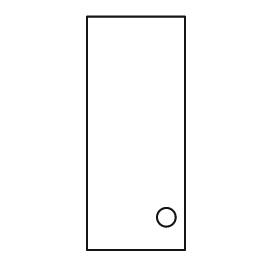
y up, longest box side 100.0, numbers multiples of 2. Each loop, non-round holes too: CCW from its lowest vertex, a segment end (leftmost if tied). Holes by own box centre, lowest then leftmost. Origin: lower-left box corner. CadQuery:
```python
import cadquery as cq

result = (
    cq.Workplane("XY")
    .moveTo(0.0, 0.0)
    .lineTo(42.0, 0.0)
    .lineTo(42.0, 100.0)
    .lineTo(0.0, 100.0)
    .close()
    .moveTo(34.0, 14.0)
    .circle(4.0)
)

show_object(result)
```